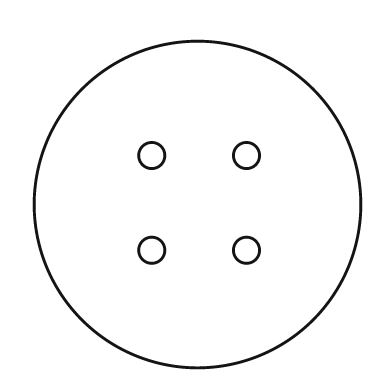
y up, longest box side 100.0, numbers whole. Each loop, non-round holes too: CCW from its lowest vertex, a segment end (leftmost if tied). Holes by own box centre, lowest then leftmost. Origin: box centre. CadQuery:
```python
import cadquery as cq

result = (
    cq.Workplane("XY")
    .moveTo(0.0, 0.0)
    .circle(50.0)
    .moveTo(-14.0, -14.0)
    .circle(4.0)
    .moveTo(15.0, -14.0)
    .circle(4.0)
    .moveTo(-14.0, 15.0)
    .circle(4.0)
    .moveTo(15.0, 15.0)
    .circle(4.0)
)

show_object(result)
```